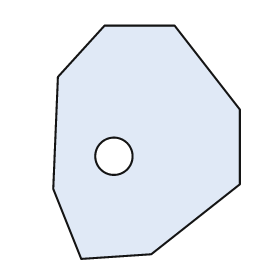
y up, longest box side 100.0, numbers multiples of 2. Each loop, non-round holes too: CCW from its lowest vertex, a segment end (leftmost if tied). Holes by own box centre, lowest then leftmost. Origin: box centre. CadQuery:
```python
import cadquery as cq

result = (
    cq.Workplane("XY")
    .moveTo(-28.0, -50.0)
    .lineTo(2.0, -48.0)
    .lineTo(40.0, -18.0)
    .lineTo(40.0, 14.0)
    .lineTo(12.0, 50.0)
    .lineTo(-18.0, 50.0)
    .lineTo(-38.0, 28.0)
    .lineTo(-40.0, -20.0)
    .close()
    .moveTo(-14.0, -6.0)
    .circle(8.0)
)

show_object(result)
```